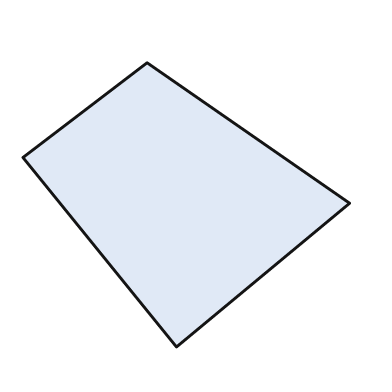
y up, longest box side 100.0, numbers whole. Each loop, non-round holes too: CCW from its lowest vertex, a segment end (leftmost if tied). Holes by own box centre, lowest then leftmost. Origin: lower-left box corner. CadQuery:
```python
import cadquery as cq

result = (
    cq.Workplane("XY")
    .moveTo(47.0, 0.0)
    .lineTo(100.0, 44.0)
    .lineTo(38.0, 87.0)
    .lineTo(0.0, 58.0)
    .close()
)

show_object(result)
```